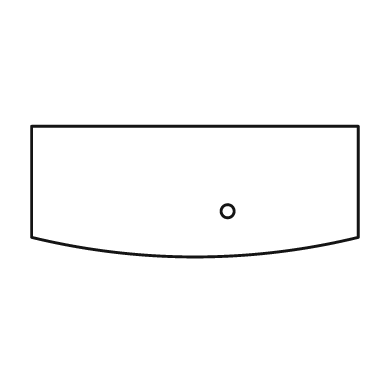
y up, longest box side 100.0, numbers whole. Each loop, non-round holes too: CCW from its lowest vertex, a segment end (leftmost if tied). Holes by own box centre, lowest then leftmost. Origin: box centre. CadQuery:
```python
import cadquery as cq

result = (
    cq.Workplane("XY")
    .moveTo(-50.0, -14.0)
    .threePointArc((0.0, -20.0), (50.0, -14.0))
    .lineTo(50.0, 20.0)
    .lineTo(-50.0, 20.0)
    .close()
    .moveTo(10.0, -6.0)
    .circle(2.0)
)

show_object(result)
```